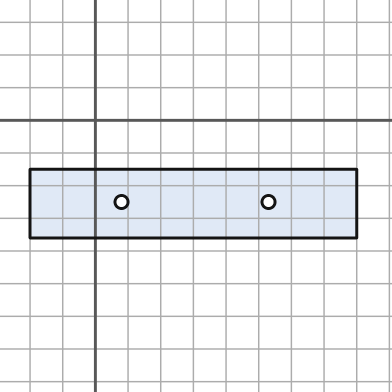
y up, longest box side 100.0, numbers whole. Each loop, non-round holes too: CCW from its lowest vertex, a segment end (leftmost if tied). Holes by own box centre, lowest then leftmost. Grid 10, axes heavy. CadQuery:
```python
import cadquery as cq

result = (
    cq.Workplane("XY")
    .moveTo(-20.0, -36.0)
    .lineTo(80.0, -36.0)
    .lineTo(80.0, -15.0)
    .lineTo(-20.0, -15.0)
    .close()
    .moveTo(8.0, -25.0)
    .circle(2.0)
    .moveTo(53.0, -25.0)
    .circle(2.0)
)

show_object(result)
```